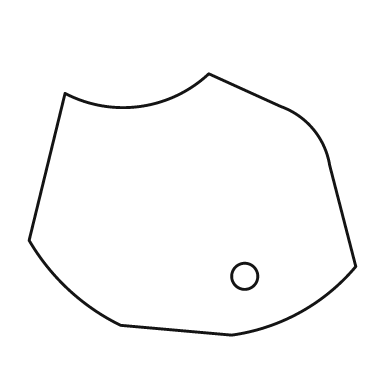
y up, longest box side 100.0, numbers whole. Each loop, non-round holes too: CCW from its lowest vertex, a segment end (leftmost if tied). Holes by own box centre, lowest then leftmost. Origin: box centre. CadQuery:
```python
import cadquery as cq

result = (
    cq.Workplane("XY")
    .moveTo(12.0, -40.0)
    .threePointArc((33.0, -33.0), (50.0, -19.0))
    .lineTo(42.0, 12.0)
    .threePointArc((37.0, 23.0), (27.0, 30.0))
    .lineTo(5.0, 40.0)
    .threePointArc((-16.0, 30.0), (-39.0, 34.0))
    .lineTo(-50.0, -11.0)
    .threePointArc((-38.0, -26.0), (-22.0, -37.0))
    .close()
    .moveTo(16.0, -22.0)
    .circle(4.0)
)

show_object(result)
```